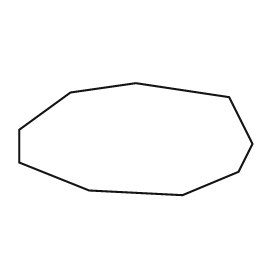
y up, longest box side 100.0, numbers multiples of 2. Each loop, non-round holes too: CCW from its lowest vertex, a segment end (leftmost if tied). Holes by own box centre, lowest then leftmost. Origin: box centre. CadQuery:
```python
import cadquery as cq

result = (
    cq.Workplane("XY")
    .moveTo(20.0, -24.0)
    .lineTo(44.0, -14.0)
    .lineTo(50.0, -2.0)
    .lineTo(40.0, 18.0)
    .lineTo(0.0, 24.0)
    .lineTo(-28.0, 20.0)
    .lineTo(-50.0, 4.0)
    .lineTo(-50.0, -10.0)
    .lineTo(-20.0, -22.0)
    .close()
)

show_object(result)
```